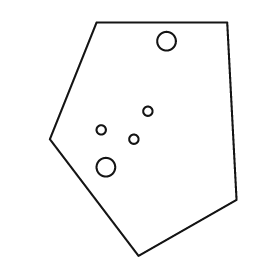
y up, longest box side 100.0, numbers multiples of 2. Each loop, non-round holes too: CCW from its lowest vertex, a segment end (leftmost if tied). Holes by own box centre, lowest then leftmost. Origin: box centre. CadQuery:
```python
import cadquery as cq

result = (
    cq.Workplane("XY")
    .moveTo(-2.0, -50.0)
    .lineTo(40.0, -26.0)
    .lineTo(36.0, 50.0)
    .lineTo(-20.0, 50.0)
    .lineTo(-40.0, 0.0)
    .close()
    .moveTo(-16.0, -12.0)
    .circle(4.0)
    .moveTo(-4.0, 0.0)
    .circle(2.0)
    .moveTo(-18.0, 4.0)
    .circle(2.0)
    .moveTo(2.0, 12.0)
    .circle(2.0)
    .moveTo(10.0, 42.0)
    .circle(4.0)
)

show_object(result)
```